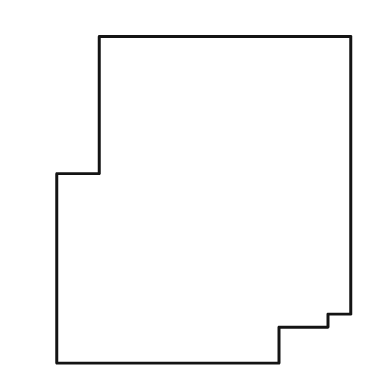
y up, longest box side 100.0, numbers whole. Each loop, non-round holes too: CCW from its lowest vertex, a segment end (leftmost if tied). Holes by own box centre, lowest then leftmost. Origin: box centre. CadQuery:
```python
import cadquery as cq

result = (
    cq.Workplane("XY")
    .moveTo(-45.0, -50.0)
    .lineTo(23.0, -50.0)
    .lineTo(23.0, -39.0)
    .lineTo(38.0, -39.0)
    .lineTo(38.0, -35.0)
    .lineTo(45.0, -35.0)
    .lineTo(45.0, 50.0)
    .lineTo(-32.0, 50.0)
    .lineTo(-32.0, 8.0)
    .lineTo(-45.0, 8.0)
    .close()
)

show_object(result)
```